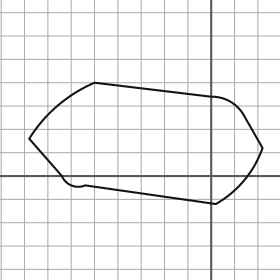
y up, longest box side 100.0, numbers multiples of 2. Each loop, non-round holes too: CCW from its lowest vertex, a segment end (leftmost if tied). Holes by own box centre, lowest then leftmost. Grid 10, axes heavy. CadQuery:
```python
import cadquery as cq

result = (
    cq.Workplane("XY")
    .moveTo(2.0, -12.0)
    .threePointArc((14.0, -2.0), (22.0, 12.0))
    .lineTo(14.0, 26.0)
    .threePointArc((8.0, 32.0), (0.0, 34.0))
    .lineTo(-50.0, 40.0)
    .threePointArc((-66.0, 30.0), (-78.0, 16.0))
    .lineTo(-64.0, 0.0)
    .threePointArc((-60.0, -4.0), (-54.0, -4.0))
    .close()
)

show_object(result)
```